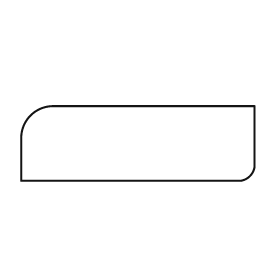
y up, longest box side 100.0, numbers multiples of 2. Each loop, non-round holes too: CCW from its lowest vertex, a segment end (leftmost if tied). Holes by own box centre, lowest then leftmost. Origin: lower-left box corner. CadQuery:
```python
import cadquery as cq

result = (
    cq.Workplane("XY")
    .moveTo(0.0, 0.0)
    .lineTo(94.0, 0.0)
    .threePointArc((98.0, 2.0), (100.0, 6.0))
    .lineTo(100.0, 32.0)
    .lineTo(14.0, 32.0)
    .threePointArc((4.0, 28.0), (0.0, 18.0))
    .close()
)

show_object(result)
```